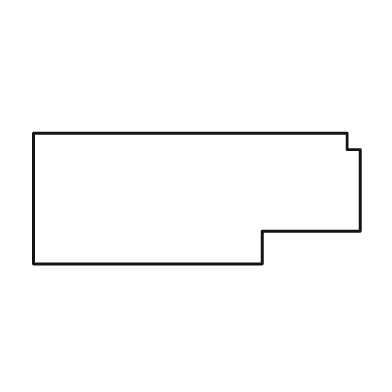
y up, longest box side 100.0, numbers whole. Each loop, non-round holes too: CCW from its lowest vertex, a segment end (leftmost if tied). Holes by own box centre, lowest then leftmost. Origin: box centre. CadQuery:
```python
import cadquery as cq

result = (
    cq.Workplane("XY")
    .moveTo(-50.0, -20.0)
    .lineTo(20.0, -20.0)
    .lineTo(20.0, -10.0)
    .lineTo(50.0, -10.0)
    .lineTo(50.0, 15.0)
    .lineTo(46.0, 15.0)
    .lineTo(46.0, 20.0)
    .lineTo(-50.0, 20.0)
    .close()
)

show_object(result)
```